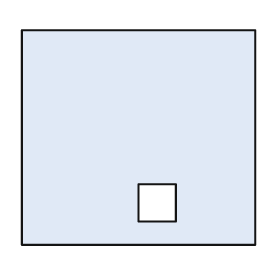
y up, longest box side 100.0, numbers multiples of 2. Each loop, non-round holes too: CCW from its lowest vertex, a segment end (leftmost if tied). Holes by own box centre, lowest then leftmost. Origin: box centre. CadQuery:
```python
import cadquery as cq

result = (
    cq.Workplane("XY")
    .moveTo(-50.0, -46.0)
    .lineTo(50.0, -46.0)
    .lineTo(50.0, 46.0)
    .lineTo(-50.0, 46.0)
    .close()
    .moveTo(0.0, -36.0)
    .lineTo(16.0, -36.0)
    .lineTo(16.0, -20.0)
    .lineTo(0.0, -20.0)
    .close()
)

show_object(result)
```